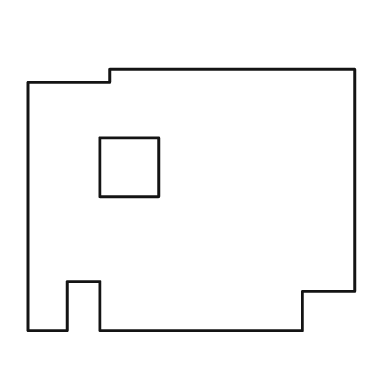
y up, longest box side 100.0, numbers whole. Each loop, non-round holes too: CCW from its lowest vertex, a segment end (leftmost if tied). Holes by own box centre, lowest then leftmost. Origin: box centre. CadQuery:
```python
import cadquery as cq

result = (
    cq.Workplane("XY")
    .moveTo(-50.0, -40.0)
    .lineTo(-38.0, -40.0)
    .lineTo(-38.0, -25.0)
    .lineTo(-28.0, -25.0)
    .lineTo(-28.0, -40.0)
    .lineTo(34.0, -40.0)
    .lineTo(34.0, -28.0)
    .lineTo(50.0, -28.0)
    .lineTo(50.0, 40.0)
    .lineTo(-25.0, 40.0)
    .lineTo(-25.0, 36.0)
    .lineTo(-50.0, 36.0)
    .close()
    .moveTo(-28.0, 1.0)
    .lineTo(-10.0, 1.0)
    .lineTo(-10.0, 19.0)
    .lineTo(-28.0, 19.0)
    .close()
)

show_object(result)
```